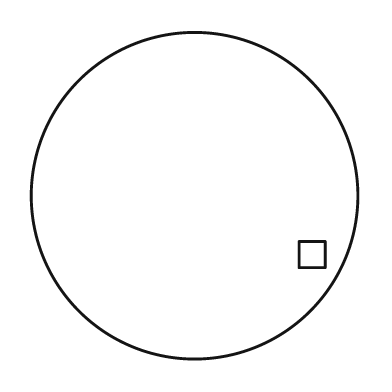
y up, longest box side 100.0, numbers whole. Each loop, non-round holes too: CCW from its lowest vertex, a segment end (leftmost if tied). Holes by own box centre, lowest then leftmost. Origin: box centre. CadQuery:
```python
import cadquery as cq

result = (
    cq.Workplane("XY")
    .moveTo(0.0, 0.0)
    .circle(50.0)
    .moveTo(32.0, -22.0)
    .lineTo(40.0, -22.0)
    .lineTo(40.0, -14.0)
    .lineTo(32.0, -14.0)
    .close()
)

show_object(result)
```